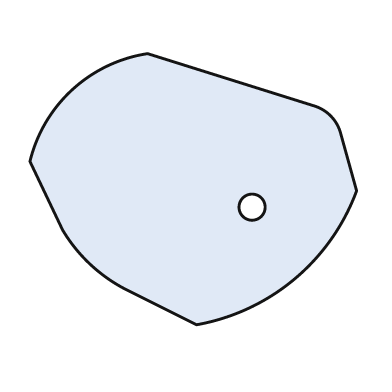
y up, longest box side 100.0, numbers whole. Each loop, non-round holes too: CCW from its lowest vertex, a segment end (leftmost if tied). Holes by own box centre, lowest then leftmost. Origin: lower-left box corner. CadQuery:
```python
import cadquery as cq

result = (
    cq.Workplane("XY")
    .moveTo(51.0, 0.0)
    .threePointArc((81.0, 14.0), (100.0, 41.0))
    .lineTo(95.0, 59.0)
    .threePointArc((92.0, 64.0), (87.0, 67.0))
    .lineTo(36.0, 83.0)
    .threePointArc((13.0, 72.0), (0.0, 50.0))
    .lineTo(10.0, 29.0)
    .threePointArc((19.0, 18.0), (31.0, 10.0))
    .close()
    .moveTo(68.0, 36.0)
    .circle(4.0)
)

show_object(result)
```